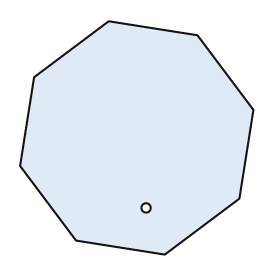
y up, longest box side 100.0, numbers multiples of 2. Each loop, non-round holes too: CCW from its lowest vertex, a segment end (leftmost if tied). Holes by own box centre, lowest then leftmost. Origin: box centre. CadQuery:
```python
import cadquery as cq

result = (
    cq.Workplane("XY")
    .moveTo(12.0, -50.0)
    .lineTo(44.0, -26.0)
    .lineTo(50.0, 12.0)
    .lineTo(26.0, 44.0)
    .lineTo(-12.0, 50.0)
    .lineTo(-44.0, 26.0)
    .lineTo(-50.0, -12.0)
    .lineTo(-26.0, -44.0)
    .close()
    .moveTo(4.0, -30.0)
    .circle(2.0)
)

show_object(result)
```